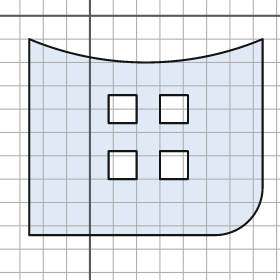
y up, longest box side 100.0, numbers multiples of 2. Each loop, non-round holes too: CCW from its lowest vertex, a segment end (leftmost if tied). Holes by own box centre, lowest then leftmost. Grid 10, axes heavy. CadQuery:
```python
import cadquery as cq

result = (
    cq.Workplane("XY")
    .moveTo(-26.0, -94.0)
    .lineTo(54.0, -94.0)
    .threePointArc((68.0, -88.0), (74.0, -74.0))
    .lineTo(74.0, -10.0)
    .threePointArc((24.0, -20.0), (-26.0, -10.0))
    .close()
    .moveTo(8.0, -70.0)
    .lineTo(20.0, -70.0)
    .lineTo(20.0, -58.0)
    .lineTo(8.0, -58.0)
    .close()
    .moveTo(30.0, -70.0)
    .lineTo(42.0, -70.0)
    .lineTo(42.0, -58.0)
    .lineTo(30.0, -58.0)
    .close()
    .moveTo(8.0, -46.0)
    .lineTo(20.0, -46.0)
    .lineTo(20.0, -34.0)
    .lineTo(8.0, -34.0)
    .close()
    .moveTo(30.0, -46.0)
    .lineTo(42.0, -46.0)
    .lineTo(42.0, -34.0)
    .lineTo(30.0, -34.0)
    .close()
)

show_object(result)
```